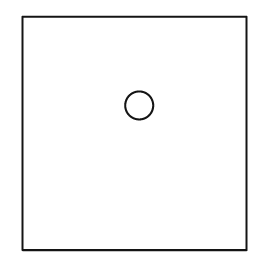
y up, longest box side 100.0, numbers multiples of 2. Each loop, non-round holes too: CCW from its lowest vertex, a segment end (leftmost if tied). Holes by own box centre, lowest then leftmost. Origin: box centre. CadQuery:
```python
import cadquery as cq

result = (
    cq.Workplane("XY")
    .moveTo(-48.0, -50.0)
    .lineTo(48.0, -50.0)
    .lineTo(48.0, 50.0)
    .lineTo(-48.0, 50.0)
    .close()
    .moveTo(2.0, 12.0)
    .circle(6.0)
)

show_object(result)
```